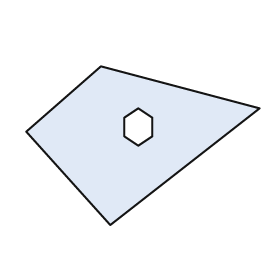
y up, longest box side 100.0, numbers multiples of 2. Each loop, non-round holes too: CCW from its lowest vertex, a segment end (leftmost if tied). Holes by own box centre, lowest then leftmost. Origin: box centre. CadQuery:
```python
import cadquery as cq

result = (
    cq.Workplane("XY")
    .moveTo(-14.0, -34.0)
    .lineTo(50.0, 16.0)
    .lineTo(-18.0, 34.0)
    .lineTo(-50.0, 6.0)
    .close()
    .moveTo(-2.0, 0.0)
    .lineTo(4.0, 4.0)
    .lineTo(4.0, 12.0)
    .lineTo(-2.0, 16.0)
    .lineTo(-8.0, 12.0)
    .lineTo(-8.0, 4.0)
    .close()
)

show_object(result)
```